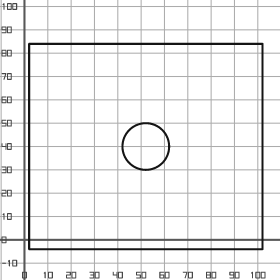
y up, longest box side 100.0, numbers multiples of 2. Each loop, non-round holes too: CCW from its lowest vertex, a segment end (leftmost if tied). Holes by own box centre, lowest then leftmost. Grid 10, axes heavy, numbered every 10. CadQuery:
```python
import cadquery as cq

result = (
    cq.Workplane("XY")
    .moveTo(2.0, -4.0)
    .lineTo(102.0, -4.0)
    .lineTo(102.0, 84.0)
    .lineTo(2.0, 84.0)
    .close()
    .moveTo(52.0, 40.0)
    .circle(10.0)
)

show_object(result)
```